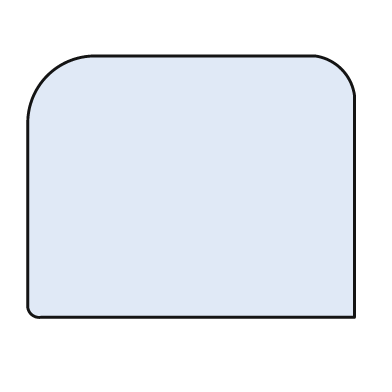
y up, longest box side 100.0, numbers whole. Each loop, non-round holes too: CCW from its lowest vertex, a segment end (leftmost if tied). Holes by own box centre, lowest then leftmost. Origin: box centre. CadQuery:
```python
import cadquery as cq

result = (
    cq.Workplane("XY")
    .moveTo(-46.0, -40.0)
    .lineTo(50.0, -40.0)
    .lineTo(50.0, 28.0)
    .threePointArc((46.0, 36.0), (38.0, 40.0))
    .lineTo(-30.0, 40.0)
    .threePointArc((-44.0, 34.0), (-50.0, 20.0))
    .lineTo(-50.0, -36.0)
    .threePointArc((-49.0, -39.0), (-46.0, -40.0))
    .close()
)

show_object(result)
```